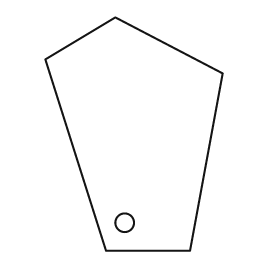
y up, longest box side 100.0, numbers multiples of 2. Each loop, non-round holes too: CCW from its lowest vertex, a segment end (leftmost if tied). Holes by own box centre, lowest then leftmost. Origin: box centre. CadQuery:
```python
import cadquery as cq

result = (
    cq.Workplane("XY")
    .moveTo(-12.0, -50.0)
    .lineTo(24.0, -50.0)
    .lineTo(38.0, 26.0)
    .lineTo(-8.0, 50.0)
    .lineTo(-38.0, 32.0)
    .close()
    .moveTo(-4.0, -38.0)
    .circle(4.0)
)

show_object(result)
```